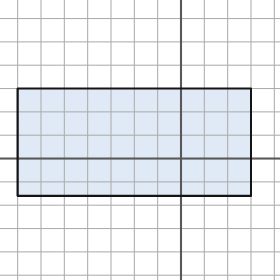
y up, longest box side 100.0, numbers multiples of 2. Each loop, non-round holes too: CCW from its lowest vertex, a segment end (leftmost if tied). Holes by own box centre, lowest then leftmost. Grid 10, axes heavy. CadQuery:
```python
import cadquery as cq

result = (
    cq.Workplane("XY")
    .moveTo(-70.0, -16.0)
    .lineTo(30.0, -16.0)
    .lineTo(30.0, 30.0)
    .lineTo(-70.0, 30.0)
    .close()
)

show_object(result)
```